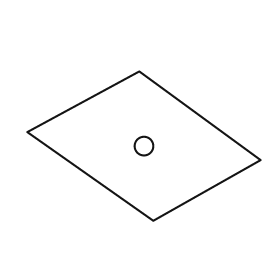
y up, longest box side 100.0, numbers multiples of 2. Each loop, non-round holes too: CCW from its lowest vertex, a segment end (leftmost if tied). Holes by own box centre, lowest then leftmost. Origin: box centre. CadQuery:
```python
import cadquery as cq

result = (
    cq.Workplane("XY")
    .moveTo(4.0, -32.0)
    .lineTo(50.0, -6.0)
    .lineTo(-2.0, 32.0)
    .lineTo(-50.0, 6.0)
    .close()
    .moveTo(0.0, 0.0)
    .circle(4.0)
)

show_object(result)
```